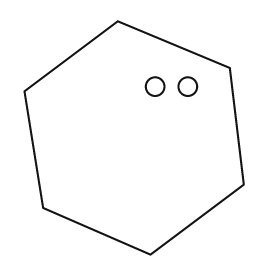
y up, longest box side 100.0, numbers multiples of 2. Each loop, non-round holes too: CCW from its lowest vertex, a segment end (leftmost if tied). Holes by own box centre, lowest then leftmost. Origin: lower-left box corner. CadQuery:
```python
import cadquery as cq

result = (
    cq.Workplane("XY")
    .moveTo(54.0, 0.0)
    .lineTo(94.0, 30.0)
    .lineTo(88.0, 80.0)
    .lineTo(40.0, 100.0)
    .lineTo(0.0, 70.0)
    .lineTo(8.0, 20.0)
    .close()
    .moveTo(56.0, 72.0)
    .circle(4.0)
    .moveTo(70.0, 72.0)
    .circle(4.0)
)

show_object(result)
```